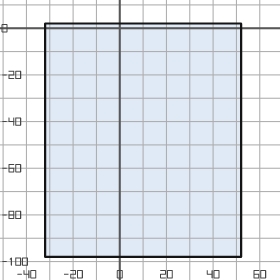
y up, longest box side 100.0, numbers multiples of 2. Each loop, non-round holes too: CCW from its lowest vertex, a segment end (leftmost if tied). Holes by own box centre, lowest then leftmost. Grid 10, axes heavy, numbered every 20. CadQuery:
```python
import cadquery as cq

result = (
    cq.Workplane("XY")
    .moveTo(-32.0, -98.0)
    .lineTo(52.0, -98.0)
    .lineTo(52.0, 2.0)
    .lineTo(-32.0, 2.0)
    .close()
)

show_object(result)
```